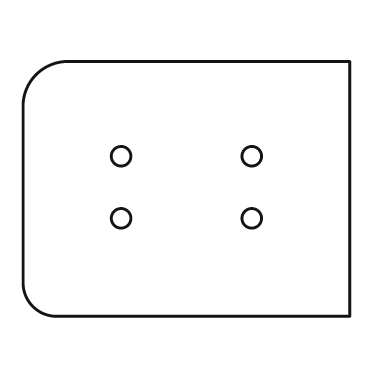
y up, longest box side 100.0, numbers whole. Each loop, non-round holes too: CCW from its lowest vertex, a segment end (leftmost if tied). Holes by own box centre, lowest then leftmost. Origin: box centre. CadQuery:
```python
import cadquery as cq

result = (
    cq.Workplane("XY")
    .moveTo(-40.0, -39.0)
    .lineTo(50.0, -39.0)
    .lineTo(50.0, 39.0)
    .lineTo(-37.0, 39.0)
    .threePointArc((-46.0, 35.0), (-50.0, 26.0))
    .lineTo(-50.0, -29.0)
    .threePointArc((-47.0, -36.0), (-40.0, -39.0))
    .close()
    .moveTo(-20.0, -9.0)
    .circle(3.0)
    .moveTo(20.0, -9.0)
    .circle(3.0)
    .moveTo(-20.0, 10.0)
    .circle(3.0)
    .moveTo(20.0, 10.0)
    .circle(3.0)
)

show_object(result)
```